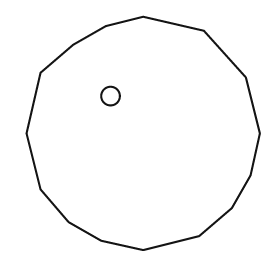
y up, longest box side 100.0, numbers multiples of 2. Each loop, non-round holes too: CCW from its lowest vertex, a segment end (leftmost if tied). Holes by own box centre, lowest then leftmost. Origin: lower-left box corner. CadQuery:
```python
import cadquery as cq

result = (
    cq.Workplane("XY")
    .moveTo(50.0, 0.0)
    .lineTo(74.0, 6.0)
    .lineTo(88.0, 18.0)
    .lineTo(96.0, 32.0)
    .lineTo(100.0, 50.0)
    .lineTo(94.0, 74.0)
    .lineTo(76.0, 94.0)
    .lineTo(50.0, 100.0)
    .lineTo(34.0, 96.0)
    .lineTo(20.0, 88.0)
    .lineTo(6.0, 76.0)
    .lineTo(0.0, 50.0)
    .lineTo(6.0, 26.0)
    .lineTo(18.0, 12.0)
    .lineTo(32.0, 4.0)
    .close()
    .moveTo(36.0, 66.0)
    .circle(4.0)
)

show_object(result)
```